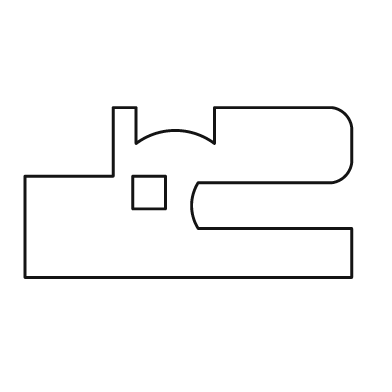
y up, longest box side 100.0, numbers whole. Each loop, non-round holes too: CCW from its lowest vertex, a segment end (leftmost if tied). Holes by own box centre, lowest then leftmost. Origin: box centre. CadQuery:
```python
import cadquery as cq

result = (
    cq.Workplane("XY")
    .moveTo(-50.0, -26.0)
    .lineTo(50.0, -26.0)
    .lineTo(50.0, -11.0)
    .lineTo(3.0, -11.0)
    .threePointArc((1.0, -4.0), (3.0, 3.0))
    .lineTo(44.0, 3.0)
    .threePointArc((48.0, 5.0), (50.0, 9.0))
    .lineTo(50.0, 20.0)
    .threePointArc((48.0, 24.0), (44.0, 26.0))
    .lineTo(8.0, 26.0)
    .lineTo(8.0, 15.0)
    .threePointArc((-4.0, 19.0), (-16.0, 15.0))
    .lineTo(-16.0, 26.0)
    .lineTo(-23.0, 26.0)
    .lineTo(-23.0, 5.0)
    .lineTo(-50.0, 5.0)
    .close()
    .moveTo(-17.0, -5.0)
    .lineTo(-7.0, -5.0)
    .lineTo(-7.0, 5.0)
    .lineTo(-17.0, 5.0)
    .close()
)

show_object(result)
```